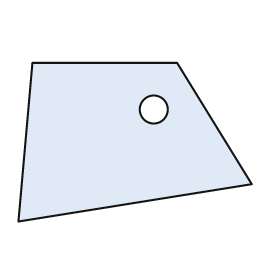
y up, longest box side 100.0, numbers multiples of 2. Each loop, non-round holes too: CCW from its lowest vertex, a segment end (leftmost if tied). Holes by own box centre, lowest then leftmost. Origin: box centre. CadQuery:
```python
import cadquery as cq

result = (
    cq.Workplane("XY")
    .moveTo(-50.0, -34.0)
    .lineTo(50.0, -18.0)
    .lineTo(18.0, 34.0)
    .lineTo(-44.0, 34.0)
    .close()
    .moveTo(8.0, 14.0)
    .circle(6.0)
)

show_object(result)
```